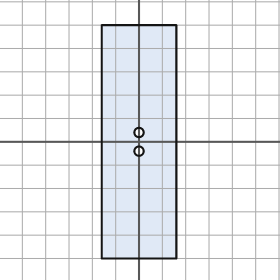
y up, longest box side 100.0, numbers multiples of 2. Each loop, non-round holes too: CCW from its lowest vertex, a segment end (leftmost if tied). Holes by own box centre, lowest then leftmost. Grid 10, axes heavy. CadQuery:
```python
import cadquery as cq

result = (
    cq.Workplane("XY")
    .moveTo(-16.0, -50.0)
    .lineTo(16.0, -50.0)
    .lineTo(16.0, 50.0)
    .lineTo(-16.0, 50.0)
    .close()
    .moveTo(0.0, -4.0)
    .circle(2.0)
    .moveTo(0.0, 4.0)
    .circle(2.0)
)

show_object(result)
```